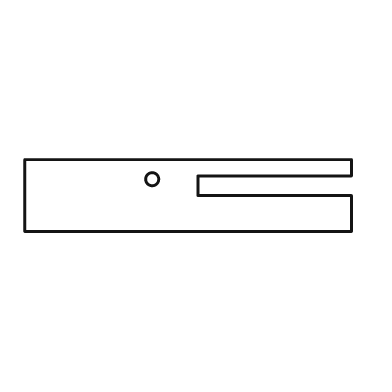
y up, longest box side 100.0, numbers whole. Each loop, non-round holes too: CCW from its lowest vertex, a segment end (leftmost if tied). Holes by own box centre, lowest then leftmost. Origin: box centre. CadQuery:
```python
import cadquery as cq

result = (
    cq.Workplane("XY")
    .moveTo(-50.0, -11.0)
    .lineTo(50.0, -11.0)
    .lineTo(50.0, 0.0)
    .lineTo(3.0, 0.0)
    .lineTo(3.0, 6.0)
    .lineTo(50.0, 6.0)
    .lineTo(50.0, 11.0)
    .lineTo(-50.0, 11.0)
    .close()
    .moveTo(-11.0, 5.0)
    .circle(2.0)
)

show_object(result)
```